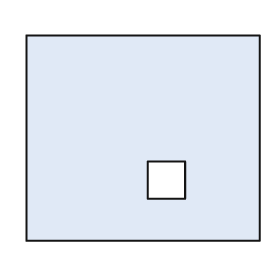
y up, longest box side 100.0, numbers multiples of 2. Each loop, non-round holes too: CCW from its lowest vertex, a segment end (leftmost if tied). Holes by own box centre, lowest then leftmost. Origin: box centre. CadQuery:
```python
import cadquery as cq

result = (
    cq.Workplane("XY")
    .moveTo(-50.0, -44.0)
    .lineTo(50.0, -44.0)
    .lineTo(50.0, 44.0)
    .lineTo(-50.0, 44.0)
    .close()
    .moveTo(2.0, -26.0)
    .lineTo(18.0, -26.0)
    .lineTo(18.0, -10.0)
    .lineTo(2.0, -10.0)
    .close()
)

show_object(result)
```